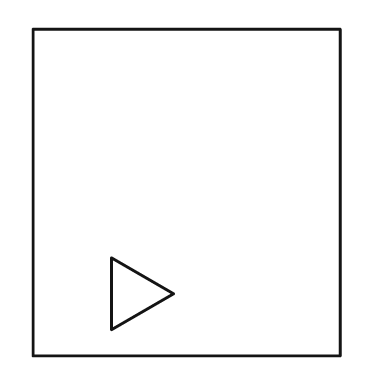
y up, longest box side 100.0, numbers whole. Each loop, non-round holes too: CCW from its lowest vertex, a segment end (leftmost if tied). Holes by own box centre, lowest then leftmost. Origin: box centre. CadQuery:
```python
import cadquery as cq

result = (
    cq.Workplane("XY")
    .moveTo(-47.0, -50.0)
    .lineTo(47.0, -50.0)
    .lineTo(47.0, 50.0)
    .lineTo(-47.0, 50.0)
    .close()
    .moveTo(-23.0, -42.0)
    .lineTo(-4.0, -31.0)
    .lineTo(-23.0, -20.0)
    .close()
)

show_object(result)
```